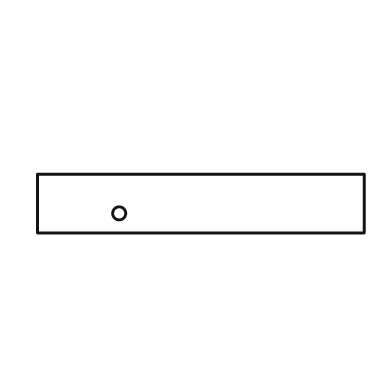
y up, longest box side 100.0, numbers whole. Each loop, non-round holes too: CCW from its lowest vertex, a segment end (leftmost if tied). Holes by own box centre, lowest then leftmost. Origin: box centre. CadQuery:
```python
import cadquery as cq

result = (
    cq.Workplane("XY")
    .moveTo(-50.0, -9.0)
    .lineTo(50.0, -9.0)
    .lineTo(50.0, 9.0)
    .lineTo(-50.0, 9.0)
    .close()
    .moveTo(-25.0, -3.0)
    .circle(2.0)
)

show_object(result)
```